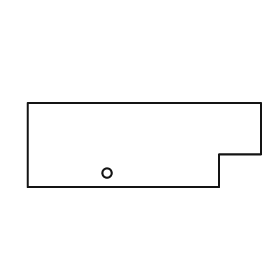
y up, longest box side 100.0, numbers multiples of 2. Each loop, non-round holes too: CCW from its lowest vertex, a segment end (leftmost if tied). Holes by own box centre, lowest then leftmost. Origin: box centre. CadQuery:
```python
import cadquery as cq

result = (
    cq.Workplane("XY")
    .moveTo(-50.0, -18.0)
    .lineTo(32.0, -18.0)
    .lineTo(32.0, -4.0)
    .lineTo(50.0, -4.0)
    .lineTo(50.0, 18.0)
    .lineTo(-50.0, 18.0)
    .close()
    .moveTo(-16.0, -12.0)
    .circle(2.0)
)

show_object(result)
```